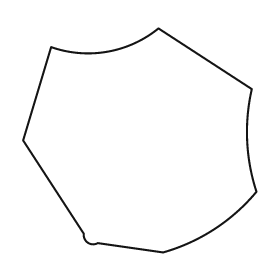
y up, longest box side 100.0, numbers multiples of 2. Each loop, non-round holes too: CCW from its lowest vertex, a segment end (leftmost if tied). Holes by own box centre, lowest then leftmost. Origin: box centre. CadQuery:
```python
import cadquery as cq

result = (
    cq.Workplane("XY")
    .moveTo(10.0, -48.0)
    .threePointArc((32.0, -38.0), (50.0, -22.0))
    .threePointArc((46.0, 0.0), (48.0, 22.0))
    .lineTo(8.0, 48.0)
    .threePointArc((-14.0, 38.0), (-38.0, 40.0))
    .lineTo(-50.0, 0.0)
    .lineTo(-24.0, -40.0)
    .threePointArc((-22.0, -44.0), (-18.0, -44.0))
    .close()
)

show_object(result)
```